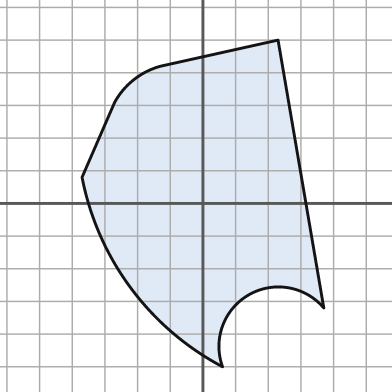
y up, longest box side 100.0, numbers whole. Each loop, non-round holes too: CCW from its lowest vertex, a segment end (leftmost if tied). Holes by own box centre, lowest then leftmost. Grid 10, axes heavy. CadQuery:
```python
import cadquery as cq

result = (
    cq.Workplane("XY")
    .moveTo(6.0, -50.0)
    .threePointArc((14.0, -28.0), (37.0, -32.0))
    .lineTo(23.0, 50.0)
    .lineTo(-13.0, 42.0)
    .threePointArc((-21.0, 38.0), (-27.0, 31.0))
    .lineTo(-37.0, 8.0)
    .threePointArc((-22.0, -26.0), (6.0, -50.0))
    .close()
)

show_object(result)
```